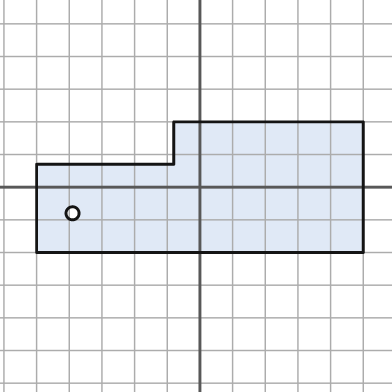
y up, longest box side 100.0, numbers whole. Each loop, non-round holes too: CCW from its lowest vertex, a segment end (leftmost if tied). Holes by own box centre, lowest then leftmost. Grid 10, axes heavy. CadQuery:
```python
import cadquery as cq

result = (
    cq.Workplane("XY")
    .moveTo(-50.0, -20.0)
    .lineTo(50.0, -20.0)
    .lineTo(50.0, 20.0)
    .lineTo(-8.0, 20.0)
    .lineTo(-8.0, 7.0)
    .lineTo(-50.0, 7.0)
    .close()
    .moveTo(-39.0, -8.0)
    .circle(2.0)
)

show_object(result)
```